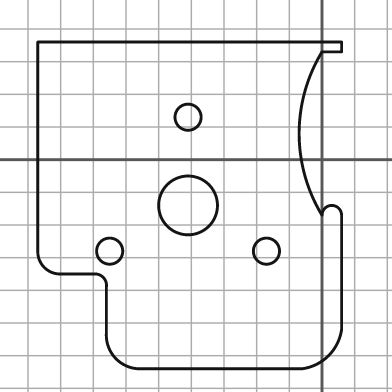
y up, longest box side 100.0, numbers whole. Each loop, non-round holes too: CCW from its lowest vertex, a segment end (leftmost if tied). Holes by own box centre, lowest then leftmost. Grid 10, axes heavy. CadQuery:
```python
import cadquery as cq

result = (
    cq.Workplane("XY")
    .moveTo(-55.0, -64.0)
    .lineTo(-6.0, -64.0)
    .threePointArc((2.0, -60.0), (6.0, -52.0))
    .lineTo(6.0, -17.0)
    .threePointArc((3.0, -14.0), (0.0, -17.0))
    .threePointArc((-7.0, 8.0), (0.0, 33.0))
    .lineTo(6.0, 33.0)
    .lineTo(6.0, 36.0)
    .lineTo(-87.0, 36.0)
    .lineTo(-87.0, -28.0)
    .threePointArc((-85.0, -33.0), (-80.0, -35.0))
    .lineTo(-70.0, -35.0)
    .threePointArc((-67.0, -36.0), (-66.0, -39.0))
    .lineTo(-66.0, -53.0)
    .threePointArc((-63.0, -61.0), (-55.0, -64.0))
    .close()
    .moveTo(-65.0, -28.0)
    .circle(4.0)
    .moveTo(-17.0, -28.0)
    .circle(4.0)
    .moveTo(-41.0, -14.0)
    .circle(9.0)
    .moveTo(-41.0, 13.0)
    .circle(4.0)
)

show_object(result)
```